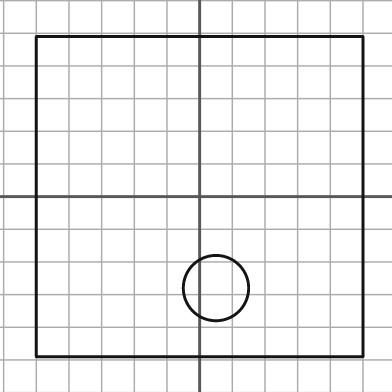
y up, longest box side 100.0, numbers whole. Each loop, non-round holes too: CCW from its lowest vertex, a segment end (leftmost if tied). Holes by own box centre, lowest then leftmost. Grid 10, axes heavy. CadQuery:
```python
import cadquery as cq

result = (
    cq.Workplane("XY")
    .moveTo(-50.0, -49.0)
    .lineTo(50.0, -49.0)
    .lineTo(50.0, 49.0)
    .lineTo(-50.0, 49.0)
    .close()
    .moveTo(5.0, -28.0)
    .circle(10.0)
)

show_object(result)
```